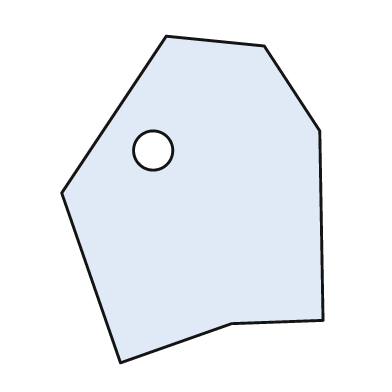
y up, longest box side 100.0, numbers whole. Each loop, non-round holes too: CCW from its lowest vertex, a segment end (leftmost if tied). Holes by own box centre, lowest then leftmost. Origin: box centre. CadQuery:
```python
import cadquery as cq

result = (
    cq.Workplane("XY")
    .moveTo(-22.0, -50.0)
    .lineTo(12.0, -38.0)
    .lineTo(40.0, -37.0)
    .lineTo(39.0, 21.0)
    .lineTo(22.0, 47.0)
    .lineTo(-8.0, 50.0)
    .lineTo(-40.0, 2.0)
    .close()
    .moveTo(-12.0, 15.0)
    .circle(6.0)
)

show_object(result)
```